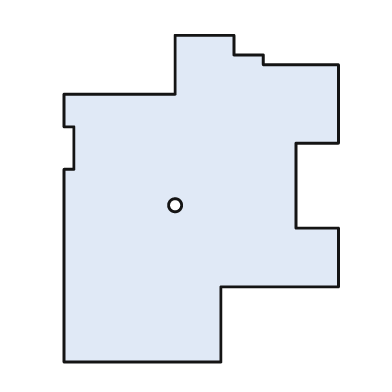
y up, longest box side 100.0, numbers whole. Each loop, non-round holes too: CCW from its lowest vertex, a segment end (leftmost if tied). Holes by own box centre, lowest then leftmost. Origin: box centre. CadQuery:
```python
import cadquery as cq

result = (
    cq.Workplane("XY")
    .moveTo(-42.0, -50.0)
    .lineTo(6.0, -50.0)
    .lineTo(6.0, -27.0)
    .lineTo(42.0, -27.0)
    .lineTo(42.0, -9.0)
    .lineTo(29.0, -9.0)
    .lineTo(29.0, 17.0)
    .lineTo(42.0, 17.0)
    .lineTo(42.0, 41.0)
    .lineTo(19.0, 41.0)
    .lineTo(19.0, 44.0)
    .lineTo(10.0, 44.0)
    .lineTo(10.0, 50.0)
    .lineTo(-8.0, 50.0)
    .lineTo(-8.0, 32.0)
    .lineTo(-42.0, 32.0)
    .lineTo(-42.0, 22.0)
    .lineTo(-39.0, 22.0)
    .lineTo(-39.0, 9.0)
    .lineTo(-42.0, 9.0)
    .close()
    .moveTo(-8.0, -2.0)
    .circle(2.0)
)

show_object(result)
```